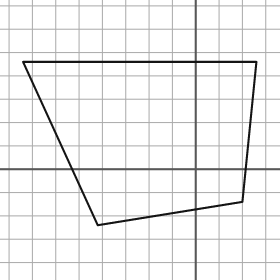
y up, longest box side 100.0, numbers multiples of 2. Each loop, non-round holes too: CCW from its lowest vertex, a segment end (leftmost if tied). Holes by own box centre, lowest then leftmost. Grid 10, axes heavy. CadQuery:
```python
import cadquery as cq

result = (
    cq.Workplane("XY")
    .moveTo(-42.0, -24.0)
    .lineTo(20.0, -14.0)
    .lineTo(26.0, 46.0)
    .lineTo(-74.0, 46.0)
    .close()
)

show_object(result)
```